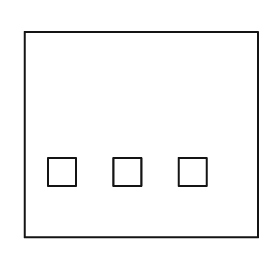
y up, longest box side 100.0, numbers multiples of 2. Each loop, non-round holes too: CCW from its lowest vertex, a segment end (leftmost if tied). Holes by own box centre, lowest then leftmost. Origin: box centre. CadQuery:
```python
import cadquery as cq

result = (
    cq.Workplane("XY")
    .moveTo(-50.0, -44.0)
    .lineTo(50.0, -44.0)
    .lineTo(50.0, 44.0)
    .lineTo(-50.0, 44.0)
    .close()
    .moveTo(-40.0, -22.0)
    .lineTo(-28.0, -22.0)
    .lineTo(-28.0, -10.0)
    .lineTo(-40.0, -10.0)
    .close()
    .moveTo(-12.0, -22.0)
    .lineTo(0.0, -22.0)
    .lineTo(0.0, -10.0)
    .lineTo(-12.0, -10.0)
    .close()
    .moveTo(16.0, -22.0)
    .lineTo(28.0, -22.0)
    .lineTo(28.0, -10.0)
    .lineTo(16.0, -10.0)
    .close()
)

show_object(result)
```